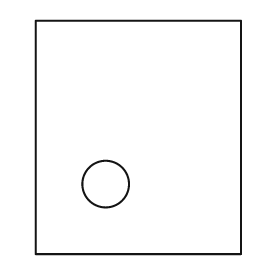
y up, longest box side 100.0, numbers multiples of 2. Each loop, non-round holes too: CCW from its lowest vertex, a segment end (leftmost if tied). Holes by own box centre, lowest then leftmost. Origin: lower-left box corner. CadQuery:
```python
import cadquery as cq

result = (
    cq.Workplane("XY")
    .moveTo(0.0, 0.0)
    .lineTo(88.0, 0.0)
    .lineTo(88.0, 100.0)
    .lineTo(0.0, 100.0)
    .close()
    .moveTo(30.0, 30.0)
    .circle(10.0)
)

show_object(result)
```